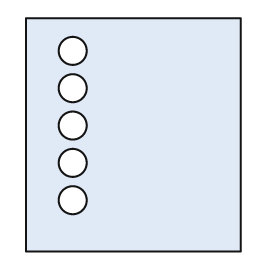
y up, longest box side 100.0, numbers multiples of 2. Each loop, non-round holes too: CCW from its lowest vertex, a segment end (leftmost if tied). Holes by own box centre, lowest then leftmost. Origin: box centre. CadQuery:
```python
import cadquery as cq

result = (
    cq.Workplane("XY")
    .moveTo(-46.0, -50.0)
    .lineTo(46.0, -50.0)
    .lineTo(46.0, 50.0)
    .lineTo(-46.0, 50.0)
    .close()
    .moveTo(-26.0, -28.0)
    .circle(6.0)
    .moveTo(-26.0, -12.0)
    .circle(6.0)
    .moveTo(-26.0, 4.0)
    .circle(6.0)
    .moveTo(-26.0, 20.0)
    .circle(6.0)
    .moveTo(-26.0, 36.0)
    .circle(6.0)
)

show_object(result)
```